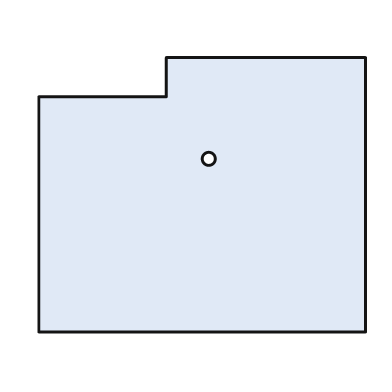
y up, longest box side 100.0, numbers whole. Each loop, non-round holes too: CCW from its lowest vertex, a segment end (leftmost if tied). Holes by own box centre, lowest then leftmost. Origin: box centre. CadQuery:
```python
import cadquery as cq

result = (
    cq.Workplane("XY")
    .moveTo(-50.0, -42.0)
    .lineTo(50.0, -42.0)
    .lineTo(50.0, 42.0)
    .lineTo(-11.0, 42.0)
    .lineTo(-11.0, 30.0)
    .lineTo(-50.0, 30.0)
    .close()
    .moveTo(2.0, 11.0)
    .circle(2.0)
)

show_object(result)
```